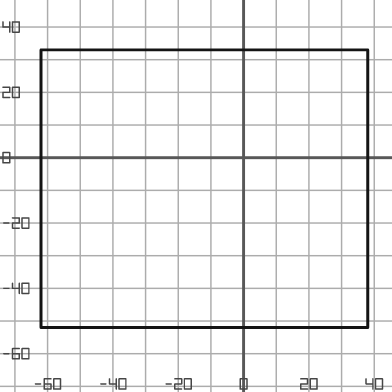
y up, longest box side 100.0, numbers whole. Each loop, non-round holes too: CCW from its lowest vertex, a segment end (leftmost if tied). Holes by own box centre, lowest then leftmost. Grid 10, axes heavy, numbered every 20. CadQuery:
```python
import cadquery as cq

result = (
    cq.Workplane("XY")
    .moveTo(-62.0, -52.0)
    .lineTo(38.0, -52.0)
    .lineTo(38.0, 33.0)
    .lineTo(-62.0, 33.0)
    .close()
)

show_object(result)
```